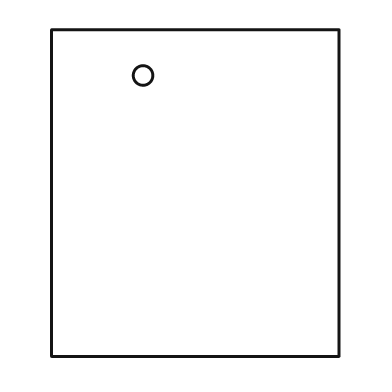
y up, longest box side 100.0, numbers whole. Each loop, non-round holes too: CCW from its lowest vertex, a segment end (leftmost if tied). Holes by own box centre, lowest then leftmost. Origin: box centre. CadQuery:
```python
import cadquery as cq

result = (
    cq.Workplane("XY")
    .moveTo(-44.0, -50.0)
    .lineTo(44.0, -50.0)
    .lineTo(44.0, 50.0)
    .lineTo(-44.0, 50.0)
    .close()
    .moveTo(-16.0, 36.0)
    .circle(3.0)
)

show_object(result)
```